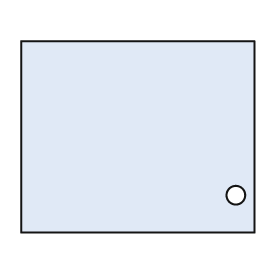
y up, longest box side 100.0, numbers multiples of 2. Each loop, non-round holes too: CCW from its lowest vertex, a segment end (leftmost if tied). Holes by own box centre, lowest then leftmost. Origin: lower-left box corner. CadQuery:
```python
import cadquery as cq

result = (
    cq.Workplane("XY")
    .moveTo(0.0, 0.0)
    .lineTo(100.0, 0.0)
    .lineTo(100.0, 82.0)
    .lineTo(0.0, 82.0)
    .close()
    .moveTo(92.0, 16.0)
    .circle(4.0)
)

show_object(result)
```